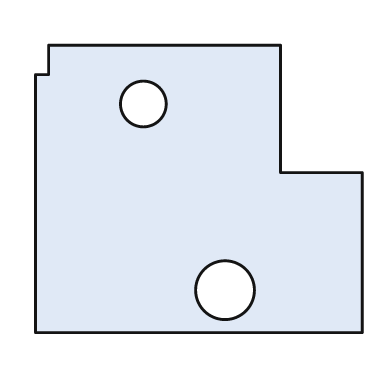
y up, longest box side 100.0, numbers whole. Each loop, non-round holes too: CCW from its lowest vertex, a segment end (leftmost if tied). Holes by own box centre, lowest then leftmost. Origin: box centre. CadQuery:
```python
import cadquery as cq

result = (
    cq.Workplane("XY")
    .moveTo(-50.0, -44.0)
    .lineTo(50.0, -44.0)
    .lineTo(50.0, 5.0)
    .lineTo(25.0, 5.0)
    .lineTo(25.0, 44.0)
    .lineTo(-46.0, 44.0)
    .lineTo(-46.0, 35.0)
    .lineTo(-50.0, 35.0)
    .close()
    .moveTo(8.0, -31.0)
    .circle(9.0)
    .moveTo(-17.0, 26.0)
    .circle(7.0)
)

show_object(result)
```